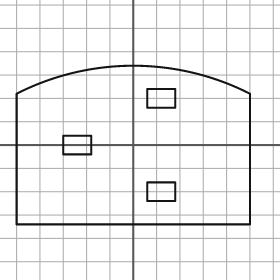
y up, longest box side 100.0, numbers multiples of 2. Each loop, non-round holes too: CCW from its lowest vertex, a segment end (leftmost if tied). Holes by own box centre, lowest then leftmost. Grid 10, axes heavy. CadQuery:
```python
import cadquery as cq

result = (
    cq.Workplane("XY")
    .moveTo(-50.0, -34.0)
    .lineTo(50.0, -34.0)
    .lineTo(50.0, 22.0)
    .threePointArc((0.0, 34.0), (-50.0, 22.0))
    .close()
    .moveTo(6.0, -24.0)
    .lineTo(18.0, -24.0)
    .lineTo(18.0, -16.0)
    .lineTo(6.0, -16.0)
    .close()
    .moveTo(-30.0, -4.0)
    .lineTo(-18.0, -4.0)
    .lineTo(-18.0, 4.0)
    .lineTo(-30.0, 4.0)
    .close()
    .moveTo(6.0, 16.0)
    .lineTo(18.0, 16.0)
    .lineTo(18.0, 24.0)
    .lineTo(6.0, 24.0)
    .close()
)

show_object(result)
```